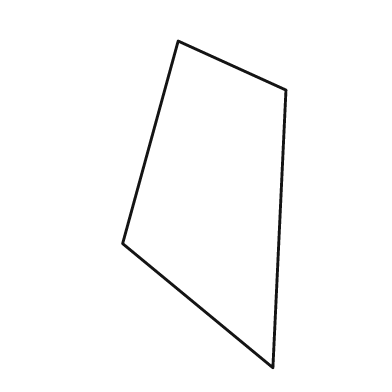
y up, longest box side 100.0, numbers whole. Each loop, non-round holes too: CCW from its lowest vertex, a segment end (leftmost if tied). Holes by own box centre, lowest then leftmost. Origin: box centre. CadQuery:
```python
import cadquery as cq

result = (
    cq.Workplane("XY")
    .moveTo(21.0, -50.0)
    .lineTo(25.0, 35.0)
    .lineTo(-8.0, 50.0)
    .lineTo(-25.0, -12.0)
    .close()
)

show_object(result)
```